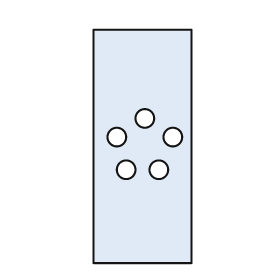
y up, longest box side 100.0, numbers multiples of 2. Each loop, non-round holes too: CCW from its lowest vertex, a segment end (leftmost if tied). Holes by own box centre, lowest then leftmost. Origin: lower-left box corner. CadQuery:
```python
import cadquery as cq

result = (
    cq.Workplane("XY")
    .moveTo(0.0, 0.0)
    .lineTo(42.0, 0.0)
    .lineTo(42.0, 100.0)
    .lineTo(0.0, 100.0)
    .close()
    .moveTo(14.0, 40.0)
    .circle(4.0)
    .moveTo(28.0, 40.0)
    .circle(4.0)
    .moveTo(10.0, 54.0)
    .circle(4.0)
    .moveTo(34.0, 54.0)
    .circle(4.0)
    .moveTo(22.0, 62.0)
    .circle(4.0)
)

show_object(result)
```